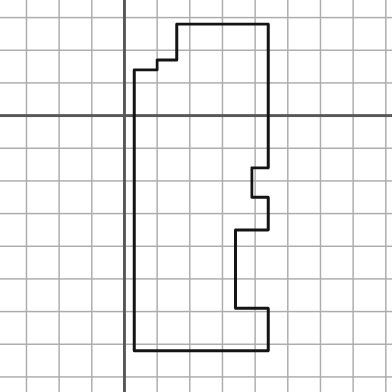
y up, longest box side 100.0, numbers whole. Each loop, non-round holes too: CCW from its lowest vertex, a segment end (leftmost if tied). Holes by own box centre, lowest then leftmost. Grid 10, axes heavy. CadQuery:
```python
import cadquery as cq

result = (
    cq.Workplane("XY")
    .moveTo(3.0, -72.0)
    .lineTo(44.0, -72.0)
    .lineTo(44.0, -59.0)
    .lineTo(34.0, -59.0)
    .lineTo(34.0, -35.0)
    .lineTo(44.0, -35.0)
    .lineTo(44.0, -25.0)
    .lineTo(39.0, -25.0)
    .lineTo(39.0, -16.0)
    .lineTo(44.0, -16.0)
    .lineTo(44.0, 28.0)
    .lineTo(16.0, 28.0)
    .lineTo(16.0, 17.0)
    .lineTo(10.0, 17.0)
    .lineTo(10.0, 14.0)
    .lineTo(3.0, 14.0)
    .close()
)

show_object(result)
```